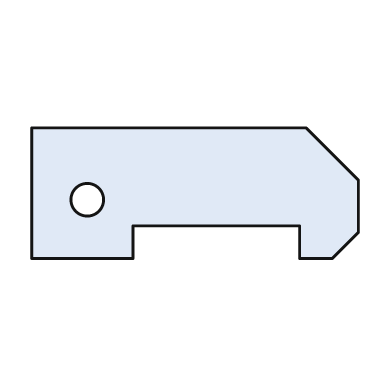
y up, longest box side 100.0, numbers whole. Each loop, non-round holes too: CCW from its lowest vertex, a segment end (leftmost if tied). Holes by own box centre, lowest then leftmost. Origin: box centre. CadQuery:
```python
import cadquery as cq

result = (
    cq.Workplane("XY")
    .moveTo(-50.0, -20.0)
    .lineTo(-19.0, -20.0)
    .lineTo(-19.0, -10.0)
    .lineTo(32.0, -10.0)
    .lineTo(32.0, -20.0)
    .lineTo(42.0, -20.0)
    .lineTo(50.0, -12.0)
    .lineTo(50.0, 4.0)
    .lineTo(34.0, 20.0)
    .lineTo(-50.0, 20.0)
    .close()
    .moveTo(-33.0, -2.0)
    .circle(5.0)
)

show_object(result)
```